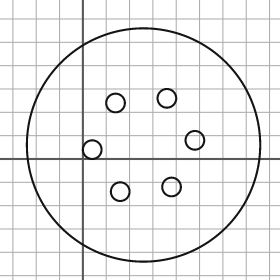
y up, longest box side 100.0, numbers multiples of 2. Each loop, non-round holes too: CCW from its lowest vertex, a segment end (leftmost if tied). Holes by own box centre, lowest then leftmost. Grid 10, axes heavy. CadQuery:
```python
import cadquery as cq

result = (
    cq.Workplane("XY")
    .moveTo(26.0, 6.0)
    .circle(50.0)
    .moveTo(16.0, -14.0)
    .circle(4.0)
    .moveTo(38.0, -12.0)
    .circle(4.0)
    .moveTo(4.0, 4.0)
    .circle(4.0)
    .moveTo(48.0, 8.0)
    .circle(4.0)
    .moveTo(14.0, 24.0)
    .circle(4.0)
    .moveTo(36.0, 26.0)
    .circle(4.0)
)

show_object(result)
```